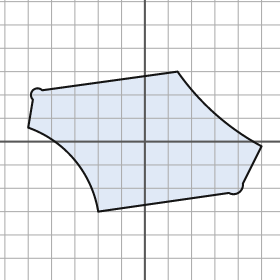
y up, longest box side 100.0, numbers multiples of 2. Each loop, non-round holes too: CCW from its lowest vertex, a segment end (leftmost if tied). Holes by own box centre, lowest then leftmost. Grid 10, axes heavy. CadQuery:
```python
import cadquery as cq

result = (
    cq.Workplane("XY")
    .moveTo(-20.0, -30.0)
    .lineTo(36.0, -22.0)
    .threePointArc((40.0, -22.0), (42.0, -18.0))
    .lineTo(50.0, -2.0)
    .threePointArc((30.0, 12.0), (14.0, 30.0))
    .lineTo(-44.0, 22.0)
    .threePointArc((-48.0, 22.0), (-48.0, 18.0))
    .lineTo(-50.0, 6.0)
    .threePointArc((-30.0, -8.0), (-20.0, -30.0))
    .close()
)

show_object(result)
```